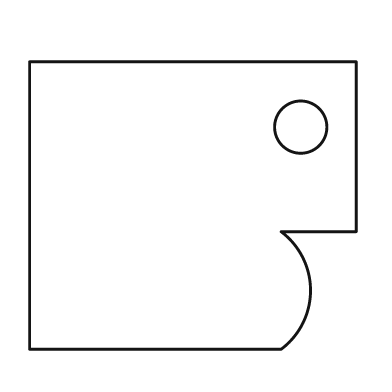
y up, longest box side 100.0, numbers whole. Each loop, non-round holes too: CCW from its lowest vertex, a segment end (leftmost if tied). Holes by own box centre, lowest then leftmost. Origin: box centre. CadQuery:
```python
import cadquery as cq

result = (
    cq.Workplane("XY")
    .moveTo(-50.0, -44.0)
    .lineTo(27.0, -44.0)
    .threePointArc((36.0, -26.0), (27.0, -8.0))
    .lineTo(50.0, -8.0)
    .lineTo(50.0, 44.0)
    .lineTo(-50.0, 44.0)
    .close()
    .moveTo(33.0, 24.0)
    .circle(8.0)
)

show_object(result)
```